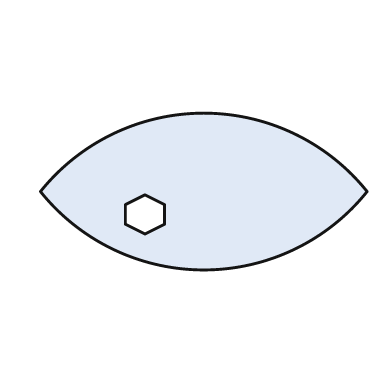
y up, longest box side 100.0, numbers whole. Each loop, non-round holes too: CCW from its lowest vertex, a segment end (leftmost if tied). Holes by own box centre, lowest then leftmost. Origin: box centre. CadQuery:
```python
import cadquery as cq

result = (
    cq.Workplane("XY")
    .moveTo(-50.0, 0.0)
    .threePointArc((0.0, -24.0), (50.0, 0.0))
    .threePointArc((0.0, 24.0), (-50.0, 0.0))
    .close()
    .moveTo(-18.0, -13.0)
    .lineTo(-12.0, -10.0)
    .lineTo(-12.0, -4.0)
    .lineTo(-18.0, -1.0)
    .lineTo(-24.0, -4.0)
    .lineTo(-24.0, -10.0)
    .close()
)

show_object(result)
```